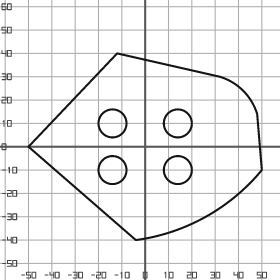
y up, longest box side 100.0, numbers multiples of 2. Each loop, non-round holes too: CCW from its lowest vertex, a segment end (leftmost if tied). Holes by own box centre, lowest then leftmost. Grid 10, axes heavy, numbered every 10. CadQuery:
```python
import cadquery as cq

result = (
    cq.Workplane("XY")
    .moveTo(-4.0, -40.0)
    .threePointArc((26.0, -30.0), (50.0, -10.0))
    .lineTo(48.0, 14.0)
    .threePointArc((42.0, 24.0), (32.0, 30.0))
    .lineTo(-12.0, 40.0)
    .lineTo(-50.0, 0.0)
    .close()
    .moveTo(-14.0, -10.0)
    .circle(6.0)
    .moveTo(14.0, -10.0)
    .circle(6.0)
    .moveTo(-14.0, 10.0)
    .circle(6.0)
    .moveTo(14.0, 10.0)
    .circle(6.0)
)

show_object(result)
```